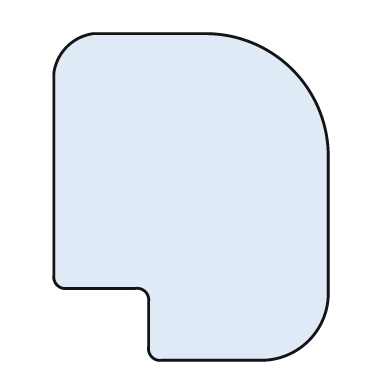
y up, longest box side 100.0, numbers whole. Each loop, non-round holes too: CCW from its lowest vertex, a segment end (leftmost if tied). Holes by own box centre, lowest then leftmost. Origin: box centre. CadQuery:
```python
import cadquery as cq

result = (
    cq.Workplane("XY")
    .moveTo(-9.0, -50.0)
    .lineTo(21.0, -50.0)
    .threePointArc((36.0, -44.0), (42.0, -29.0))
    .lineTo(42.0, 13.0)
    .threePointArc((31.0, 39.0), (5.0, 50.0))
    .lineTo(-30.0, 50.0)
    .threePointArc((-38.0, 46.0), (-42.0, 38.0))
    .lineTo(-42.0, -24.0)
    .threePointArc((-41.0, -27.0), (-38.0, -28.0))
    .lineTo(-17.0, -28.0)
    .threePointArc((-14.0, -29.0), (-13.0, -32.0))
    .lineTo(-13.0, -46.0)
    .threePointArc((-12.0, -49.0), (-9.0, -50.0))
    .close()
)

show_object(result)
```